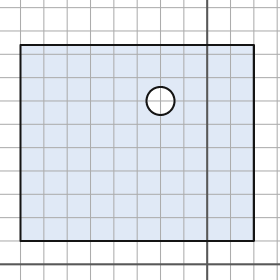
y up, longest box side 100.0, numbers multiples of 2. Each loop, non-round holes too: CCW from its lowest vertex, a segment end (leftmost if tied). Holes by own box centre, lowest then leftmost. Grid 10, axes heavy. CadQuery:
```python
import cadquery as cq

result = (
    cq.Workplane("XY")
    .moveTo(-80.0, 10.0)
    .lineTo(20.0, 10.0)
    .lineTo(20.0, 94.0)
    .lineTo(-80.0, 94.0)
    .close()
    .moveTo(-20.0, 70.0)
    .circle(6.0)
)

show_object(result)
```